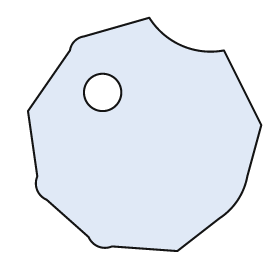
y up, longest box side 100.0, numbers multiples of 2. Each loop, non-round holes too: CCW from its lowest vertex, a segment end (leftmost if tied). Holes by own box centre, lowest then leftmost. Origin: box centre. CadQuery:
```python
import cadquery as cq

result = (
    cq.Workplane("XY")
    .moveTo(14.0, -50.0)
    .lineTo(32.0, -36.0)
    .threePointArc((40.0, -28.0), (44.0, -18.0))
    .lineTo(50.0, 4.0)
    .lineTo(34.0, 36.0)
    .threePointArc((16.0, 38.0), (2.0, 50.0))
    .lineTo(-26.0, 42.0)
    .threePointArc((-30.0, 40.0), (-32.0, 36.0))
    .lineTo(-50.0, 10.0)
    .lineTo(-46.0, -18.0)
    .threePointArc((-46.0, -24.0), (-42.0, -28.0))
    .lineTo(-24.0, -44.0)
    .threePointArc((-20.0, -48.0), (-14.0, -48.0))
    .close()
    .moveTo(-18.0, 18.0)
    .circle(8.0)
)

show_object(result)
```